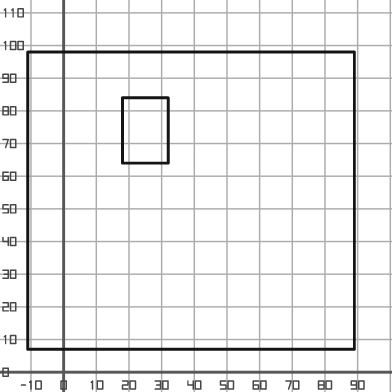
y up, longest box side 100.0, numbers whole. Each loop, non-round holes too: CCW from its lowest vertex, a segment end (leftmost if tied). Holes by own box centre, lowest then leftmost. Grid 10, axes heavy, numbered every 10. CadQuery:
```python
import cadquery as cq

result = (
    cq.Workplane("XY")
    .moveTo(-11.0, 7.0)
    .lineTo(89.0, 7.0)
    .lineTo(89.0, 98.0)
    .lineTo(-11.0, 98.0)
    .close()
    .moveTo(18.0, 64.0)
    .lineTo(32.0, 64.0)
    .lineTo(32.0, 84.0)
    .lineTo(18.0, 84.0)
    .close()
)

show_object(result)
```